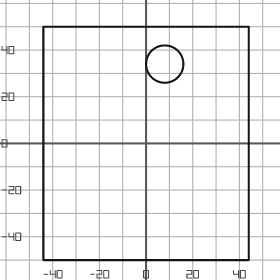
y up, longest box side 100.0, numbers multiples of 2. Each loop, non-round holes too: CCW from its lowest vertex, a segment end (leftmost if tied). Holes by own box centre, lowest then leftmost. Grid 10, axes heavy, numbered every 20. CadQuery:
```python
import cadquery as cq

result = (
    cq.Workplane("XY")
    .moveTo(-44.0, -50.0)
    .lineTo(44.0, -50.0)
    .lineTo(44.0, 50.0)
    .lineTo(-44.0, 50.0)
    .close()
    .moveTo(8.0, 34.0)
    .circle(8.0)
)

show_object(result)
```